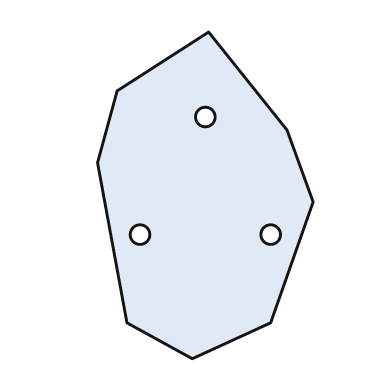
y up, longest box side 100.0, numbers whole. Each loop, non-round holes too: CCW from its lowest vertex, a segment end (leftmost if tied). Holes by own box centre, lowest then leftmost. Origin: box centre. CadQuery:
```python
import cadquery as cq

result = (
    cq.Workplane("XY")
    .moveTo(-4.0, -50.0)
    .lineTo(20.0, -39.0)
    .lineTo(33.0, -2.0)
    .lineTo(25.0, 20.0)
    .lineTo(1.0, 50.0)
    .lineTo(-27.0, 32.0)
    .lineTo(-33.0, 10.0)
    .lineTo(-24.0, -39.0)
    .close()
    .moveTo(-20.0, -12.0)
    .circle(3.0)
    .moveTo(20.0, -12.0)
    .circle(3.0)
    .moveTo(0.0, 24.0)
    .circle(3.0)
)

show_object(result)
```